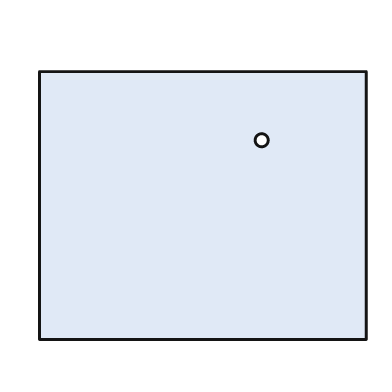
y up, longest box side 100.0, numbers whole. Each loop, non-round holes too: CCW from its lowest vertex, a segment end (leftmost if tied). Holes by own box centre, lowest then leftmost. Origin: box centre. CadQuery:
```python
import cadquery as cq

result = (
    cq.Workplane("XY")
    .moveTo(-50.0, -41.0)
    .lineTo(50.0, -41.0)
    .lineTo(50.0, 41.0)
    .lineTo(-50.0, 41.0)
    .close()
    .moveTo(18.0, 20.0)
    .circle(2.0)
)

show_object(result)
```